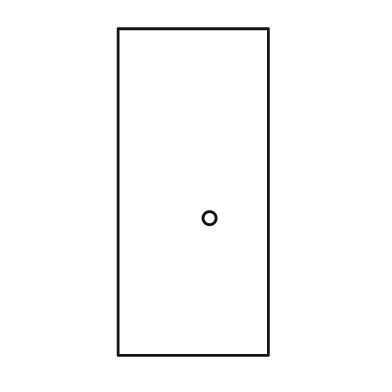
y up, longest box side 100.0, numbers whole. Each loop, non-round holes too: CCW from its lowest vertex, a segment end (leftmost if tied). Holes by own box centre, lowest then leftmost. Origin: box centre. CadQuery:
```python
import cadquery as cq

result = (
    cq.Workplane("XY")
    .moveTo(-23.0, -50.0)
    .lineTo(23.0, -50.0)
    .lineTo(23.0, 50.0)
    .lineTo(-23.0, 50.0)
    .close()
    .moveTo(5.0, -8.0)
    .circle(2.0)
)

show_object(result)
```